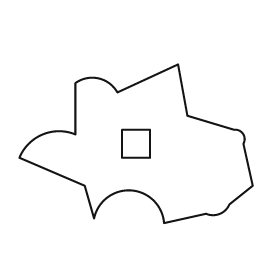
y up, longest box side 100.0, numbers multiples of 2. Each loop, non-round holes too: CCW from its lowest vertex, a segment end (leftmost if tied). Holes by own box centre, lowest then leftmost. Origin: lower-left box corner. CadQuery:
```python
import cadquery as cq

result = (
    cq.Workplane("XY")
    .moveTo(62.0, 0.0)
    .lineTo(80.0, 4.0)
    .threePointArc((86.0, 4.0), (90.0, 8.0))
    .lineTo(100.0, 16.0)
    .lineTo(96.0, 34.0)
    .threePointArc((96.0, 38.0), (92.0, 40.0))
    .lineTo(72.0, 46.0)
    .lineTo(68.0, 68.0)
    .lineTo(42.0, 56.0)
    .threePointArc((34.0, 62.0), (24.0, 60.0))
    .lineTo(24.0, 38.0)
    .threePointArc((10.0, 38.0), (0.0, 28.0))
    .lineTo(28.0, 16.0)
    .lineTo(32.0, 2.0)
    .threePointArc((48.0, 14.0), (62.0, 0.0))
    .close()
    .moveTo(44.0, 28.0)
    .lineTo(56.0, 28.0)
    .lineTo(56.0, 40.0)
    .lineTo(44.0, 40.0)
    .close()
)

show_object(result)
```